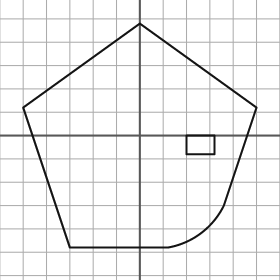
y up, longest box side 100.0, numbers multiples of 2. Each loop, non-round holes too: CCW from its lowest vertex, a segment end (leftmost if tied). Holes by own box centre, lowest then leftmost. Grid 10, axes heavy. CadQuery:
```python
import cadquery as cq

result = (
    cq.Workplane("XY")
    .moveTo(-30.0, -48.0)
    .lineTo(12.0, -48.0)
    .threePointArc((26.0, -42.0), (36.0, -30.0))
    .lineTo(50.0, 12.0)
    .lineTo(0.0, 48.0)
    .lineTo(-50.0, 12.0)
    .close()
    .moveTo(20.0, -8.0)
    .lineTo(32.0, -8.0)
    .lineTo(32.0, 0.0)
    .lineTo(20.0, 0.0)
    .close()
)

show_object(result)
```